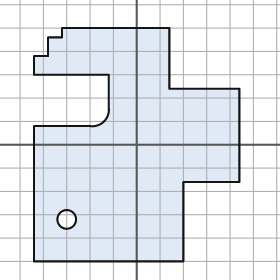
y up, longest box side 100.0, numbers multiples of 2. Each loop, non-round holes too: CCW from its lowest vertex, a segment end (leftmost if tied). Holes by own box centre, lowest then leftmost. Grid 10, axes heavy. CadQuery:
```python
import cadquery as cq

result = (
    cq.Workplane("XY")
    .moveTo(-44.0, -50.0)
    .lineTo(20.0, -50.0)
    .lineTo(20.0, -16.0)
    .lineTo(44.0, -16.0)
    .lineTo(44.0, 24.0)
    .lineTo(14.0, 24.0)
    .lineTo(14.0, 50.0)
    .lineTo(-32.0, 50.0)
    .lineTo(-32.0, 46.0)
    .lineTo(-38.0, 46.0)
    .lineTo(-38.0, 38.0)
    .lineTo(-44.0, 38.0)
    .lineTo(-44.0, 30.0)
    .lineTo(-12.0, 30.0)
    .lineTo(-12.0, 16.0)
    .threePointArc((-14.0, 10.0), (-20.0, 8.0))
    .lineTo(-44.0, 8.0)
    .close()
    .moveTo(-30.0, -32.0)
    .circle(4.0)
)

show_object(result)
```